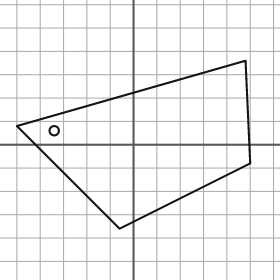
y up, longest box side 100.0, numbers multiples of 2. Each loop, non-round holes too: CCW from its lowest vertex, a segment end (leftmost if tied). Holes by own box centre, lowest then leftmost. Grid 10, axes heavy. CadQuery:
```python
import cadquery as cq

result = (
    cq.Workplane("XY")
    .moveTo(-6.0, -36.0)
    .lineTo(50.0, -8.0)
    .lineTo(48.0, 36.0)
    .lineTo(-50.0, 8.0)
    .close()
    .moveTo(-34.0, 6.0)
    .circle(2.0)
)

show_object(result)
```